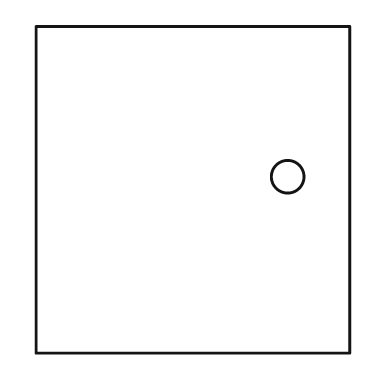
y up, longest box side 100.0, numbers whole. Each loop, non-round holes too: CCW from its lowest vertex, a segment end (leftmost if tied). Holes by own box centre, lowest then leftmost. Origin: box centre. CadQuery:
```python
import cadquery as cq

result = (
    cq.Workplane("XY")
    .moveTo(-48.0, -50.0)
    .lineTo(48.0, -50.0)
    .lineTo(48.0, 50.0)
    .lineTo(-48.0, 50.0)
    .close()
    .moveTo(29.0, 4.0)
    .circle(5.0)
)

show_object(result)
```